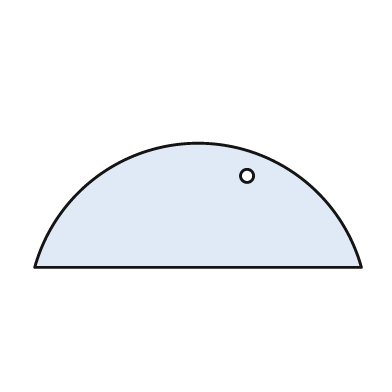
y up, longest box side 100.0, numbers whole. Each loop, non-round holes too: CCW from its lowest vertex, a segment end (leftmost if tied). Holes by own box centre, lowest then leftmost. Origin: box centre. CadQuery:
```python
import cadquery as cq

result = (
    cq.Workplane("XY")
    .moveTo(-50.0, -19.0)
    .lineTo(50.0, -19.0)
    .threePointArc((0.0, 19.0), (-50.0, -19.0))
    .close()
    .moveTo(15.0, 9.0)
    .circle(2.0)
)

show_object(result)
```